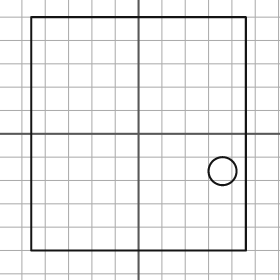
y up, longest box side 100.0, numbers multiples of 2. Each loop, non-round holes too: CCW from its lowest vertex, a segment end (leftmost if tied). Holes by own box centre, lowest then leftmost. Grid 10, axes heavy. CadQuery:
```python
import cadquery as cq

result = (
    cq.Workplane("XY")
    .moveTo(-46.0, -50.0)
    .lineTo(46.0, -50.0)
    .lineTo(46.0, 50.0)
    .lineTo(-46.0, 50.0)
    .close()
    .moveTo(36.0, -16.0)
    .circle(6.0)
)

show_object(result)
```